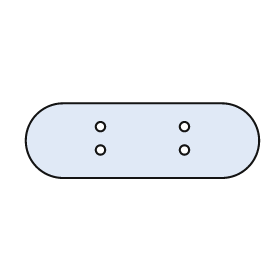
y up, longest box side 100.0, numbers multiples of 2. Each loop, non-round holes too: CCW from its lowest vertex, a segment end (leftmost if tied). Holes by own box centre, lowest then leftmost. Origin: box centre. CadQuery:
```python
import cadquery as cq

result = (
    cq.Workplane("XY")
    .moveTo(-34.0, -16.0)
    .lineTo(34.0, -16.0)
    .threePointArc((50.0, 0.0), (34.0, 16.0))
    .lineTo(-34.0, 16.0)
    .threePointArc((-50.0, 0.0), (-34.0, -16.0))
    .close()
    .moveTo(-18.0, -4.0)
    .circle(2.0)
    .moveTo(18.0, -4.0)
    .circle(2.0)
    .moveTo(-18.0, 6.0)
    .circle(2.0)
    .moveTo(18.0, 6.0)
    .circle(2.0)
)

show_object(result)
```